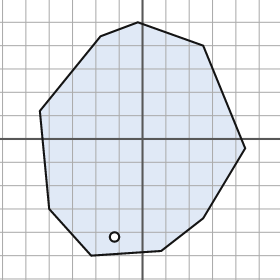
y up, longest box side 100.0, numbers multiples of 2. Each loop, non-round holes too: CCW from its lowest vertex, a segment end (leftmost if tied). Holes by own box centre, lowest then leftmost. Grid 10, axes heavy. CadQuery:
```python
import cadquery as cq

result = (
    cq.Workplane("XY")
    .moveTo(-22.0, -50.0)
    .lineTo(8.0, -48.0)
    .lineTo(26.0, -34.0)
    .lineTo(44.0, -4.0)
    .lineTo(26.0, 40.0)
    .lineTo(-2.0, 50.0)
    .lineTo(-18.0, 44.0)
    .lineTo(-44.0, 12.0)
    .lineTo(-40.0, -30.0)
    .close()
    .moveTo(-12.0, -42.0)
    .circle(2.0)
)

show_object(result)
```